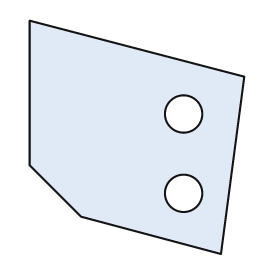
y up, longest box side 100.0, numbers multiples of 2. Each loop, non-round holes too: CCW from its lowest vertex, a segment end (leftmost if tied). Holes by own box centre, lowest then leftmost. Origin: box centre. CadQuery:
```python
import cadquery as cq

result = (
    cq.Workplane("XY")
    .moveTo(36.0, -50.0)
    .lineTo(46.0, 26.0)
    .lineTo(-46.0, 50.0)
    .lineTo(-46.0, -12.0)
    .lineTo(-24.0, -34.0)
    .close()
    .moveTo(20.0, -24.0)
    .circle(8.0)
    .moveTo(20.0, 10.0)
    .circle(8.0)
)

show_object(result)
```